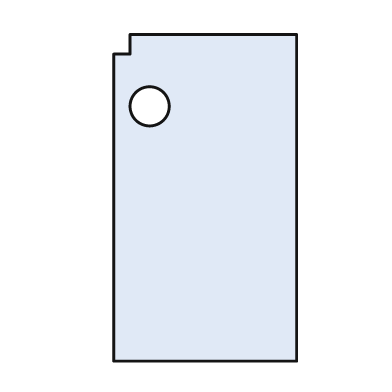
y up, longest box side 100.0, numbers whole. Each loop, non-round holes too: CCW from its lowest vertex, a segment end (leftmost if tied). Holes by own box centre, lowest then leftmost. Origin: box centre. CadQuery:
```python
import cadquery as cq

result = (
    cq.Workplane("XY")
    .moveTo(-28.0, -50.0)
    .lineTo(28.0, -50.0)
    .lineTo(28.0, 50.0)
    .lineTo(-23.0, 50.0)
    .lineTo(-23.0, 44.0)
    .lineTo(-28.0, 44.0)
    .close()
    .moveTo(-17.0, 28.0)
    .circle(6.0)
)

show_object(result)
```